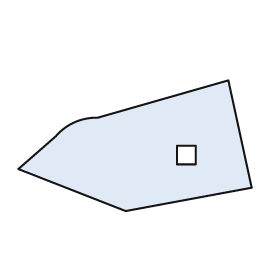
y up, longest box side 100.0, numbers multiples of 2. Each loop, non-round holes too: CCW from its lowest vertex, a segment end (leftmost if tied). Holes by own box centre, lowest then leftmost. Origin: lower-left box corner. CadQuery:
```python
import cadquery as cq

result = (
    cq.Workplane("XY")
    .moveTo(46.0, 0.0)
    .lineTo(100.0, 10.0)
    .lineTo(90.0, 56.0)
    .lineTo(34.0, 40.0)
    .threePointArc((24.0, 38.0), (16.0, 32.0))
    .lineTo(0.0, 18.0)
    .close()
    .moveTo(68.0, 20.0)
    .lineTo(76.0, 20.0)
    .lineTo(76.0, 28.0)
    .lineTo(68.0, 28.0)
    .close()
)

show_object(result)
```